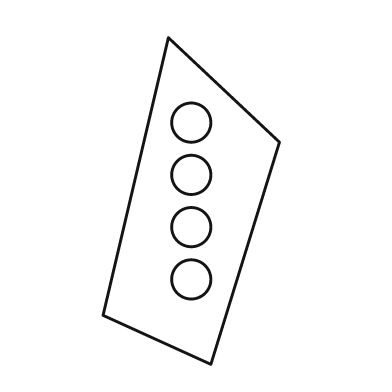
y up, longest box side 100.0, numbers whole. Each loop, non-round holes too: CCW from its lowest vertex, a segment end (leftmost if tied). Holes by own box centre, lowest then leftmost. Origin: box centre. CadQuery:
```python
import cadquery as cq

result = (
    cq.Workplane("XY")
    .moveTo(6.0, -50.0)
    .lineTo(27.0, 18.0)
    .lineTo(-7.0, 50.0)
    .lineTo(-27.0, -35.0)
    .close()
    .moveTo(0.0, -24.0)
    .circle(6.0)
    .moveTo(0.0, -8.0)
    .circle(6.0)
    .moveTo(0.0, 8.0)
    .circle(6.0)
    .moveTo(0.0, 24.0)
    .circle(6.0)
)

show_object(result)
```